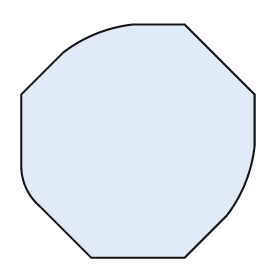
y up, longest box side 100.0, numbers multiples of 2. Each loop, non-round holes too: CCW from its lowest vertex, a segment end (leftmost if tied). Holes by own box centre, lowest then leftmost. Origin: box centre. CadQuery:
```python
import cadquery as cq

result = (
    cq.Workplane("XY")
    .moveTo(-20.0, -50.0)
    .lineTo(20.0, -50.0)
    .lineTo(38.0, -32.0)
    .threePointArc((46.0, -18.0), (50.0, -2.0))
    .lineTo(50.0, 20.0)
    .lineTo(20.0, 50.0)
    .lineTo(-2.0, 50.0)
    .threePointArc((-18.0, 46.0), (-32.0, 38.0))
    .lineTo(-50.0, 20.0)
    .lineTo(-50.0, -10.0)
    .threePointArc((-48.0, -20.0), (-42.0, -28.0))
    .close()
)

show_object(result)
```